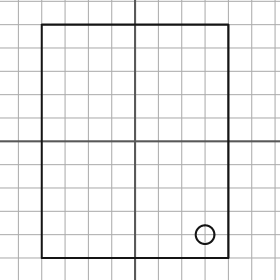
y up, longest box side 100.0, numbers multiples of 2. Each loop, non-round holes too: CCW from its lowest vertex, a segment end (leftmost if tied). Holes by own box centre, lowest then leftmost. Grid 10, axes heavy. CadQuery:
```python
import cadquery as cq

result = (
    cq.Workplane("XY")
    .moveTo(-40.0, -50.0)
    .lineTo(40.0, -50.0)
    .lineTo(40.0, 50.0)
    .lineTo(-40.0, 50.0)
    .close()
    .moveTo(30.0, -40.0)
    .circle(4.0)
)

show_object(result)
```